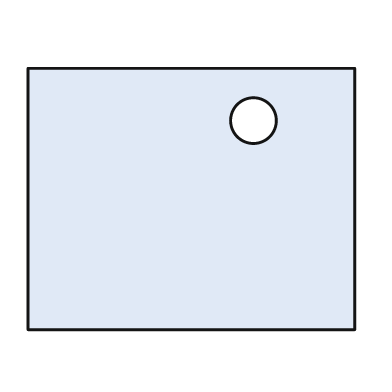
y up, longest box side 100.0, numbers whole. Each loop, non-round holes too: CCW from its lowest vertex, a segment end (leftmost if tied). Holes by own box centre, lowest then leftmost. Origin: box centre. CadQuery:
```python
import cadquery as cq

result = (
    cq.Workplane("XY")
    .moveTo(-50.0, -40.0)
    .lineTo(50.0, -40.0)
    .lineTo(50.0, 40.0)
    .lineTo(-50.0, 40.0)
    .close()
    .moveTo(19.0, 24.0)
    .circle(7.0)
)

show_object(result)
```